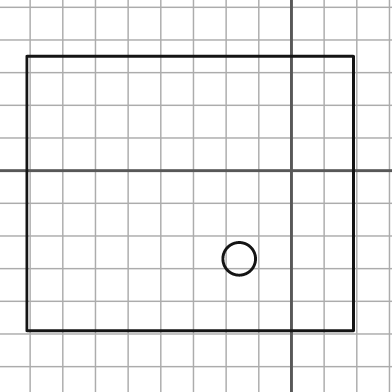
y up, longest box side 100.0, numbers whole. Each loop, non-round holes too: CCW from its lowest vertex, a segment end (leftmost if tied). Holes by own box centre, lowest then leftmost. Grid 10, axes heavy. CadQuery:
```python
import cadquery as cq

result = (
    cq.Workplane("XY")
    .moveTo(-81.0, -49.0)
    .lineTo(19.0, -49.0)
    .lineTo(19.0, 35.0)
    .lineTo(-81.0, 35.0)
    .close()
    .moveTo(-16.0, -27.0)
    .circle(5.0)
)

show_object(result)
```